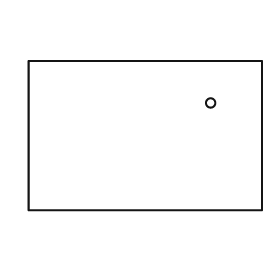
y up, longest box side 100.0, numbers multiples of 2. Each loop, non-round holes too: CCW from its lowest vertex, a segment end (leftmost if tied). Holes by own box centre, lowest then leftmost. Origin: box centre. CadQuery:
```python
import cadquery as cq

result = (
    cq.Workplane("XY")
    .moveTo(-50.0, -32.0)
    .lineTo(50.0, -32.0)
    .lineTo(50.0, 32.0)
    .lineTo(-50.0, 32.0)
    .close()
    .moveTo(28.0, 14.0)
    .circle(2.0)
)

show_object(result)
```